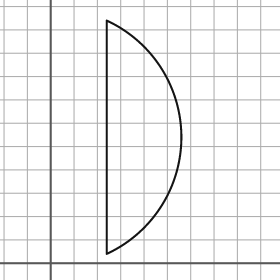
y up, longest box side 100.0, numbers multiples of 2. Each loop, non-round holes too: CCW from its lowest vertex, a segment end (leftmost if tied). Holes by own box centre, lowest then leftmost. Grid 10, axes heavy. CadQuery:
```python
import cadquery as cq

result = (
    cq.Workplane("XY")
    .moveTo(24.0, 4.0)
    .threePointArc((56.0, 54.0), (24.0, 104.0))
    .close()
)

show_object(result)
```